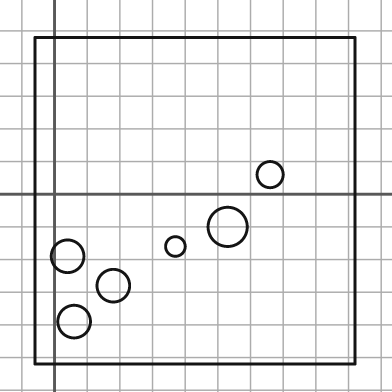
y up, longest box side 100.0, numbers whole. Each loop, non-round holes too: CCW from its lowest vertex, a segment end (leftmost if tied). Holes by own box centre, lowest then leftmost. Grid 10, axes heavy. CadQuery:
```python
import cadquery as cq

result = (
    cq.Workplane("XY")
    .moveTo(-6.0, -52.0)
    .lineTo(92.0, -52.0)
    .lineTo(92.0, 48.0)
    .lineTo(-6.0, 48.0)
    .close()
    .moveTo(6.0, -39.0)
    .circle(5.0)
    .moveTo(18.0, -28.0)
    .circle(5.0)
    .moveTo(4.0, -19.0)
    .circle(5.0)
    .moveTo(37.0, -16.0)
    .circle(3.0)
    .moveTo(53.0, -10.0)
    .circle(6.0)
    .moveTo(66.0, 6.0)
    .circle(4.0)
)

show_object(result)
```